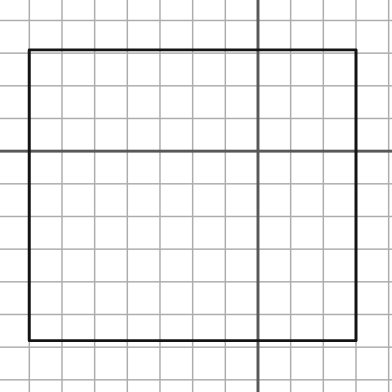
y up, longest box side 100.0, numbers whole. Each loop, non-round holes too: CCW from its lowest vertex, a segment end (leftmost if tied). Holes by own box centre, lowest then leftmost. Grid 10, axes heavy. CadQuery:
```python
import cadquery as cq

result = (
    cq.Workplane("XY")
    .moveTo(-70.0, -58.0)
    .lineTo(30.0, -58.0)
    .lineTo(30.0, 31.0)
    .lineTo(-70.0, 31.0)
    .close()
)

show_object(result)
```